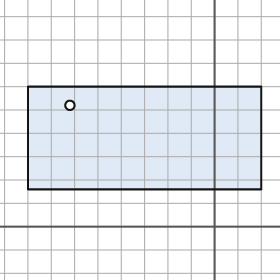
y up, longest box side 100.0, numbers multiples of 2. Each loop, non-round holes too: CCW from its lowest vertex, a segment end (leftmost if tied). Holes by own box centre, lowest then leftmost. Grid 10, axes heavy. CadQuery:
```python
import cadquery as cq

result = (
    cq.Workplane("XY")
    .moveTo(-80.0, 16.0)
    .lineTo(20.0, 16.0)
    .lineTo(20.0, 60.0)
    .lineTo(-80.0, 60.0)
    .close()
    .moveTo(-62.0, 52.0)
    .circle(2.0)
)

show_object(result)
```